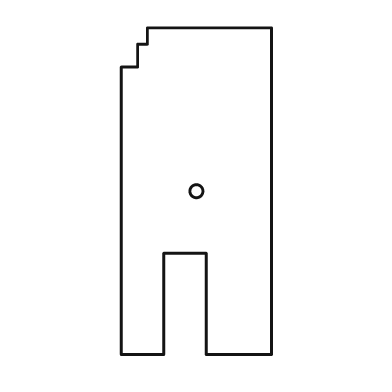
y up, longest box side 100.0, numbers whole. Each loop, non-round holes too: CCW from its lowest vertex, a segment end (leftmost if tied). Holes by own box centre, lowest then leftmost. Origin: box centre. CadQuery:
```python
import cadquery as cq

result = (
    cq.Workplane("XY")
    .moveTo(-23.0, -50.0)
    .lineTo(-10.0, -50.0)
    .lineTo(-10.0, -19.0)
    .lineTo(3.0, -19.0)
    .lineTo(3.0, -50.0)
    .lineTo(23.0, -50.0)
    .lineTo(23.0, 50.0)
    .lineTo(-15.0, 50.0)
    .lineTo(-15.0, 45.0)
    .lineTo(-18.0, 45.0)
    .lineTo(-18.0, 38.0)
    .lineTo(-23.0, 38.0)
    .close()
    .moveTo(0.0, 0.0)
    .circle(2.0)
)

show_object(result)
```